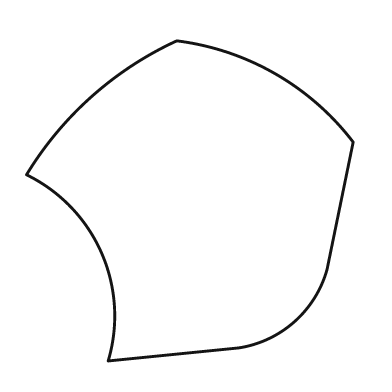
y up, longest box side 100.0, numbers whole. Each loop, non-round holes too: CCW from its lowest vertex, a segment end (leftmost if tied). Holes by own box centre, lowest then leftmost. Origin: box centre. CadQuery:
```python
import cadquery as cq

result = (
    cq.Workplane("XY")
    .moveTo(-25.0, -49.0)
    .lineTo(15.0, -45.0)
    .threePointArc((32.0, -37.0), (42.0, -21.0))
    .lineTo(50.0, 18.0)
    .threePointArc((26.0, 39.0), (-4.0, 49.0))
    .threePointArc((-30.0, 32.0), (-50.0, 8.0))
    .threePointArc((-27.0, -16.0), (-25.0, -49.0))
    .close()
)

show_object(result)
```